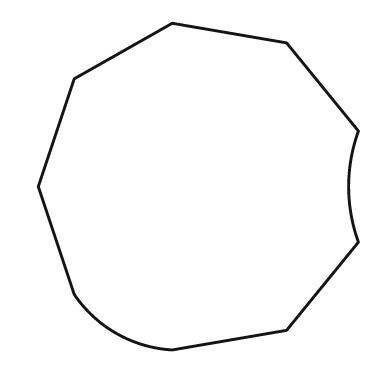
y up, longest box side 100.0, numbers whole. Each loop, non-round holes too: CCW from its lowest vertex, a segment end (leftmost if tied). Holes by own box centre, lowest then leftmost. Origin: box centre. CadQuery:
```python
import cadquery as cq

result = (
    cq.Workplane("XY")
    .moveTo(-8.0, -50.0)
    .lineTo(27.0, -44.0)
    .lineTo(49.0, -17.0)
    .threePointArc((46.0, 0.0), (49.0, 17.0))
    .lineTo(27.0, 44.0)
    .lineTo(-8.0, 50.0)
    .lineTo(-38.0, 33.0)
    .lineTo(-49.0, 0.0)
    .lineTo(-38.0, -33.0)
    .threePointArc((-25.0, -45.0), (-8.0, -50.0))
    .close()
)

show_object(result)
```